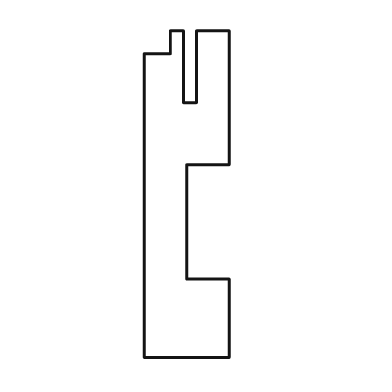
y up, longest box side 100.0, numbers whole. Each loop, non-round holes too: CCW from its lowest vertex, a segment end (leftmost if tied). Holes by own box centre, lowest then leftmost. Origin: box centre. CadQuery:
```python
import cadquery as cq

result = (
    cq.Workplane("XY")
    .moveTo(-13.0, -50.0)
    .lineTo(13.0, -50.0)
    .lineTo(13.0, -26.0)
    .lineTo(0.0, -26.0)
    .lineTo(0.0, 9.0)
    .lineTo(13.0, 9.0)
    .lineTo(13.0, 50.0)
    .lineTo(3.0, 50.0)
    .lineTo(3.0, 28.0)
    .lineTo(-1.0, 28.0)
    .lineTo(-1.0, 50.0)
    .lineTo(-5.0, 50.0)
    .lineTo(-5.0, 43.0)
    .lineTo(-13.0, 43.0)
    .close()
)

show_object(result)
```